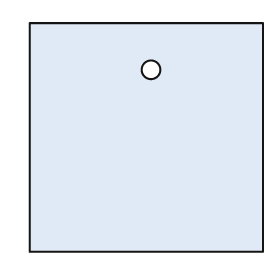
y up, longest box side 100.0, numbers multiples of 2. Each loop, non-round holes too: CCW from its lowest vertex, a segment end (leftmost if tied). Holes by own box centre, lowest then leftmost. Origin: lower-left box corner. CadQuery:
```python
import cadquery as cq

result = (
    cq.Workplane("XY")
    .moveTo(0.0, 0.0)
    .lineTo(100.0, 0.0)
    .lineTo(100.0, 98.0)
    .lineTo(0.0, 98.0)
    .close()
    .moveTo(52.0, 78.0)
    .circle(4.0)
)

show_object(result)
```